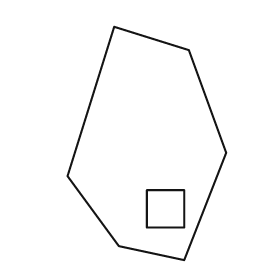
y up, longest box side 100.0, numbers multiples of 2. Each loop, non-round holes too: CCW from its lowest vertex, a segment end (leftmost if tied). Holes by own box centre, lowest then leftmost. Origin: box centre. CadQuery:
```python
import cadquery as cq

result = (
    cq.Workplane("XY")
    .moveTo(16.0, -50.0)
    .lineTo(34.0, -4.0)
    .lineTo(18.0, 40.0)
    .lineTo(-14.0, 50.0)
    .lineTo(-34.0, -14.0)
    .lineTo(-12.0, -44.0)
    .close()
    .moveTo(0.0, -36.0)
    .lineTo(16.0, -36.0)
    .lineTo(16.0, -20.0)
    .lineTo(0.0, -20.0)
    .close()
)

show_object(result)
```